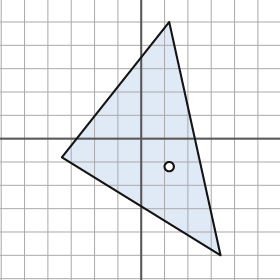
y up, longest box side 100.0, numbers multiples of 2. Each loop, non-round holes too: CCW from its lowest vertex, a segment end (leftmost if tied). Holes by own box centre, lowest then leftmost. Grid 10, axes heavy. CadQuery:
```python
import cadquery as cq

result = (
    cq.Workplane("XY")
    .moveTo(34.0, -50.0)
    .lineTo(12.0, 50.0)
    .lineTo(-34.0, -8.0)
    .close()
    .moveTo(12.0, -12.0)
    .circle(2.0)
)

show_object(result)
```